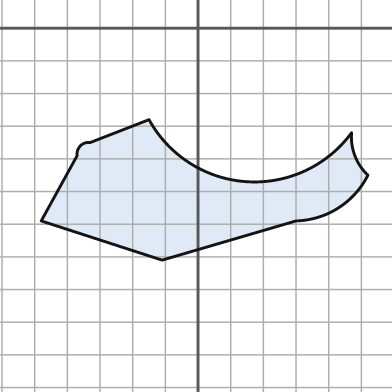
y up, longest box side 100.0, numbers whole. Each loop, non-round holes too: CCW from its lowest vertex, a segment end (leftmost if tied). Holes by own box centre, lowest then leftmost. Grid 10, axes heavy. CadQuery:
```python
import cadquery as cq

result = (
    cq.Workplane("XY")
    .moveTo(-11.0, -71.0)
    .lineTo(30.0, -59.0)
    .threePointArc((43.0, -55.0), (52.0, -45.0))
    .threePointArc((48.0, -39.0), (47.0, -32.0))
    .threePointArc((15.0, -47.0), (-15.0, -28.0))
    .lineTo(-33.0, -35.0)
    .threePointArc((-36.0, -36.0), (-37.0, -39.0))
    .lineTo(-48.0, -59.0)
    .close()
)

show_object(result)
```